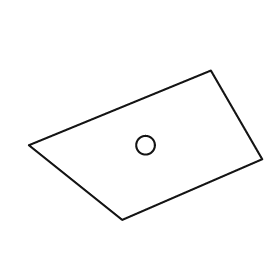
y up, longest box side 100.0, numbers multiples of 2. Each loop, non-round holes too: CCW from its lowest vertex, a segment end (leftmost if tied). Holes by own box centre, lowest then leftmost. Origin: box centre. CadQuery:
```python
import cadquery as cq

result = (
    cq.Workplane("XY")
    .moveTo(-10.0, -32.0)
    .lineTo(50.0, -6.0)
    .lineTo(28.0, 32.0)
    .lineTo(-50.0, 0.0)
    .close()
    .moveTo(0.0, 0.0)
    .circle(4.0)
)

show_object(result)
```